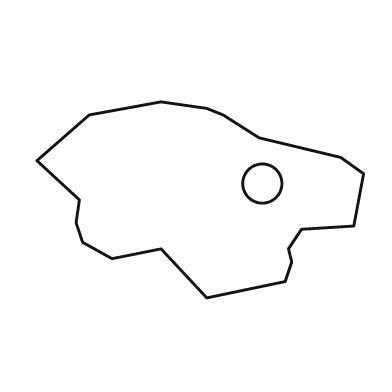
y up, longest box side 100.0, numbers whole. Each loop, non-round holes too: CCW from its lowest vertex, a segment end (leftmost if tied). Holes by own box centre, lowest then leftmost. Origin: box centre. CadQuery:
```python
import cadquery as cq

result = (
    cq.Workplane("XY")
    .moveTo(2.0, -30.0)
    .lineTo(26.0, -25.0)
    .lineTo(28.0, -19.0)
    .lineTo(27.0, -15.0)
    .lineTo(31.0, -9.0)
    .lineTo(47.0, -8.0)
    .lineTo(50.0, 8.0)
    .lineTo(43.0, 13.0)
    .lineTo(18.0, 19.0)
    .lineTo(7.0, 26.0)
    .lineTo(2.0, 28.0)
    .lineTo(-12.0, 30.0)
    .lineTo(-34.0, 26.0)
    .lineTo(-50.0, 12.0)
    .lineTo(-37.0, 0.0)
    .lineTo(-38.0, -7.0)
    .lineTo(-36.0, -13.0)
    .lineTo(-27.0, -18.0)
    .lineTo(-12.0, -15.0)
    .close()
    .moveTo(19.0, 5.0)
    .circle(6.0)
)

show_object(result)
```